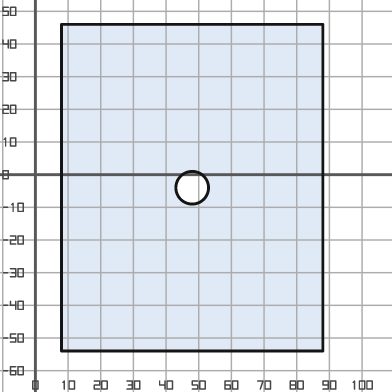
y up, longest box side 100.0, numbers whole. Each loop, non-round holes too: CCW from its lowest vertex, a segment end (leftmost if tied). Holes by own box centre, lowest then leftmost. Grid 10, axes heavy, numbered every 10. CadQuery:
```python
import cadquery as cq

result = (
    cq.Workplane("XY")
    .moveTo(8.0, -54.0)
    .lineTo(88.0, -54.0)
    .lineTo(88.0, 46.0)
    .lineTo(8.0, 46.0)
    .close()
    .moveTo(48.0, -4.0)
    .circle(5.0)
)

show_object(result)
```